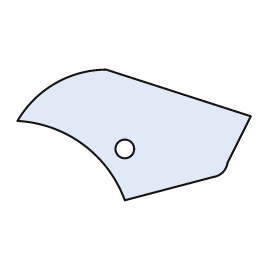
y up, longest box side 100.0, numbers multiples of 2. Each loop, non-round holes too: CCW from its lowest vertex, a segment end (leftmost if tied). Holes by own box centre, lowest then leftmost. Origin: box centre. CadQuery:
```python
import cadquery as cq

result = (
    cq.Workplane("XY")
    .moveTo(-4.0, -28.0)
    .lineTo(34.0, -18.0)
    .threePointArc((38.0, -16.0), (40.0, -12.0))
    .lineTo(50.0, 8.0)
    .lineTo(-12.0, 28.0)
    .threePointArc((-34.0, 22.0), (-50.0, 6.0))
    .threePointArc((-22.0, -4.0), (-4.0, -28.0))
    .close()
    .moveTo(-4.0, -6.0)
    .circle(4.0)
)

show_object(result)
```